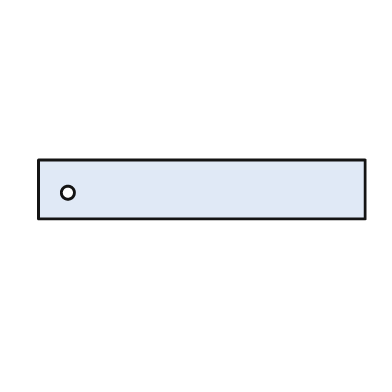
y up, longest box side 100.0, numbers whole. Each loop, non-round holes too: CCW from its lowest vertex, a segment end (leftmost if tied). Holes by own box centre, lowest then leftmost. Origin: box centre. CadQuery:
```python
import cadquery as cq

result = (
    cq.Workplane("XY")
    .moveTo(-50.0, -9.0)
    .lineTo(50.0, -9.0)
    .lineTo(50.0, 9.0)
    .lineTo(-50.0, 9.0)
    .close()
    .moveTo(-41.0, -1.0)
    .circle(2.0)
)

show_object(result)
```